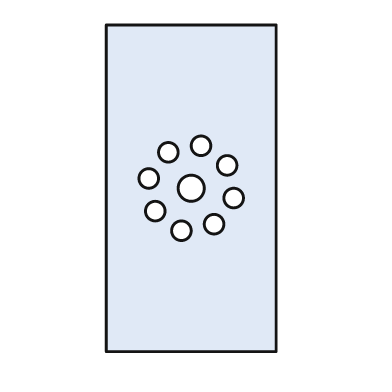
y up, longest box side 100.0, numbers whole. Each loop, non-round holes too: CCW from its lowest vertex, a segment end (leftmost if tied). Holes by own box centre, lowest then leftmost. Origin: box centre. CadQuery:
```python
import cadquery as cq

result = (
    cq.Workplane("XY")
    .moveTo(-26.0, -50.0)
    .lineTo(26.0, -50.0)
    .lineTo(26.0, 50.0)
    .lineTo(-26.0, 50.0)
    .close()
    .moveTo(-3.0, -13.0)
    .circle(3.0)
    .moveTo(7.0, -11.0)
    .circle(3.0)
    .moveTo(-11.0, -7.0)
    .circle(3.0)
    .moveTo(13.0, -3.0)
    .circle(3.0)
    .moveTo(0.0, 0.0)
    .circle(4.0)
    .moveTo(-13.0, 3.0)
    .circle(3.0)
    .moveTo(11.0, 7.0)
    .circle(3.0)
    .moveTo(-7.0, 11.0)
    .circle(3.0)
    .moveTo(3.0, 13.0)
    .circle(3.0)
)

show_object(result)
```